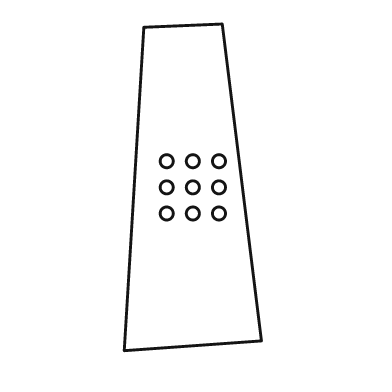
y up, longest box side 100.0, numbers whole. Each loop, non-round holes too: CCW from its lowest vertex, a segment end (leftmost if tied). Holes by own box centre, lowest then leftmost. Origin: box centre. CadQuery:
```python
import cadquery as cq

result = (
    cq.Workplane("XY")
    .moveTo(-21.0, -50.0)
    .lineTo(21.0, -47.0)
    .lineTo(9.0, 50.0)
    .lineTo(-15.0, 49.0)
    .close()
    .moveTo(-8.0, -8.0)
    .circle(2.0)
    .moveTo(0.0, -8.0)
    .circle(2.0)
    .moveTo(8.0, -8.0)
    .circle(2.0)
    .moveTo(-8.0, 0.0)
    .circle(2.0)
    .moveTo(0.0, 0.0)
    .circle(2.0)
    .moveTo(8.0, 0.0)
    .circle(2.0)
    .moveTo(-8.0, 8.0)
    .circle(2.0)
    .moveTo(0.0, 8.0)
    .circle(2.0)
    .moveTo(8.0, 8.0)
    .circle(2.0)
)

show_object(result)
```